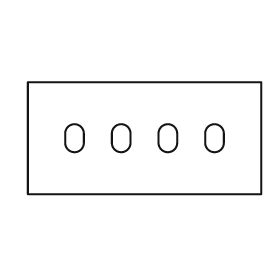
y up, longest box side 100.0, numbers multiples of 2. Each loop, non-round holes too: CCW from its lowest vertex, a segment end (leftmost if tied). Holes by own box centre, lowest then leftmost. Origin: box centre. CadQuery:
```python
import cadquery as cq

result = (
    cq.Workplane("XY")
    .moveTo(-50.0, -24.0)
    .lineTo(50.0, -24.0)
    .lineTo(50.0, 24.0)
    .lineTo(-50.0, 24.0)
    .close()
    .moveTo(-34.0, -2.0)
    .threePointArc((-30.0, -6.0), (-26.0, -2.0))
    .lineTo(-26.0, 2.0)
    .threePointArc((-30.0, 6.0), (-34.0, 2.0))
    .close()
    .moveTo(-14.0, -2.0)
    .threePointArc((-10.0, -6.0), (-6.0, -2.0))
    .lineTo(-6.0, 2.0)
    .threePointArc((-10.0, 6.0), (-14.0, 2.0))
    .close()
    .moveTo(6.0, -2.0)
    .threePointArc((10.0, -6.0), (14.0, -2.0))
    .lineTo(14.0, 2.0)
    .threePointArc((10.0, 6.0), (6.0, 2.0))
    .close()
    .moveTo(26.0, -2.0)
    .threePointArc((30.0, -6.0), (34.0, -2.0))
    .lineTo(34.0, 2.0)
    .threePointArc((30.0, 6.0), (26.0, 2.0))
    .close()
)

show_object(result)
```